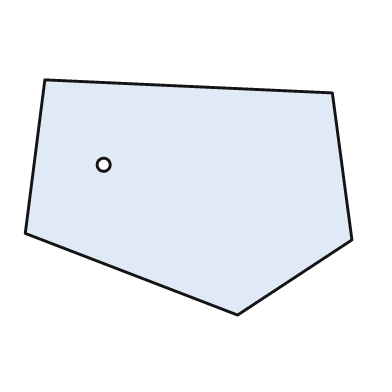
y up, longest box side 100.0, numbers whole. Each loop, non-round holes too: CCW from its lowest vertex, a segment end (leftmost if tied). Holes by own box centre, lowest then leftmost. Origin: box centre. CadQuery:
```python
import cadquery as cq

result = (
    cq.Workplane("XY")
    .moveTo(15.0, -36.0)
    .lineTo(50.0, -13.0)
    .lineTo(44.0, 32.0)
    .lineTo(-44.0, 36.0)
    .lineTo(-50.0, -11.0)
    .close()
    .moveTo(-26.0, 10.0)
    .circle(2.0)
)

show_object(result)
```